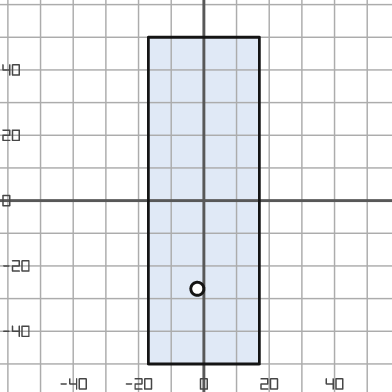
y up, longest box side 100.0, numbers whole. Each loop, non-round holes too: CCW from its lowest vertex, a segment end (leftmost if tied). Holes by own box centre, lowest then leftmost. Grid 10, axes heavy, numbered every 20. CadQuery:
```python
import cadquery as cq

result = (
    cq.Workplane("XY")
    .moveTo(-17.0, -50.0)
    .lineTo(17.0, -50.0)
    .lineTo(17.0, 50.0)
    .lineTo(-17.0, 50.0)
    .close()
    .moveTo(-2.0, -27.0)
    .circle(2.0)
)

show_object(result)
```